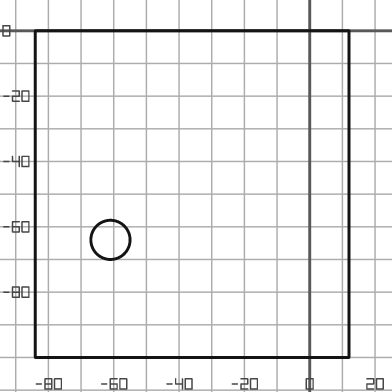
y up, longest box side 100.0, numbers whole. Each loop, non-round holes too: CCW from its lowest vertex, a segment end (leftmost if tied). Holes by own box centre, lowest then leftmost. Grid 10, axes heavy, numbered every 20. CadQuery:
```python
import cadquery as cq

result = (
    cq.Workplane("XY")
    .moveTo(-84.0, -100.0)
    .lineTo(12.0, -100.0)
    .lineTo(12.0, 0.0)
    .lineTo(-84.0, 0.0)
    .close()
    .moveTo(-61.0, -64.0)
    .circle(6.0)
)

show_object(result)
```